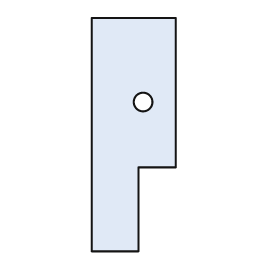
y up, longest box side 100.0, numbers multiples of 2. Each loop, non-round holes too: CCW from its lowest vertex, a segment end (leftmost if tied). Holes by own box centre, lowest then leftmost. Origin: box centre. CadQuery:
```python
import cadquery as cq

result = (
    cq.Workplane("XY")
    .moveTo(-18.0, -50.0)
    .lineTo(2.0, -50.0)
    .lineTo(2.0, -14.0)
    .lineTo(18.0, -14.0)
    .lineTo(18.0, 50.0)
    .lineTo(-18.0, 50.0)
    .close()
    .moveTo(4.0, 14.0)
    .circle(4.0)
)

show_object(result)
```